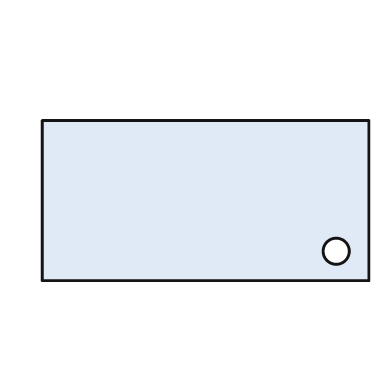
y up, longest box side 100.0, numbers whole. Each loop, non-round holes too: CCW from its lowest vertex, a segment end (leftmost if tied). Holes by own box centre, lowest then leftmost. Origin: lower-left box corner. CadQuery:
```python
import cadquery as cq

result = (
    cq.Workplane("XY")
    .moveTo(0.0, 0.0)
    .lineTo(100.0, 0.0)
    .lineTo(100.0, 49.0)
    .lineTo(0.0, 49.0)
    .close()
    .moveTo(90.0, 9.0)
    .circle(4.0)
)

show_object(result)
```